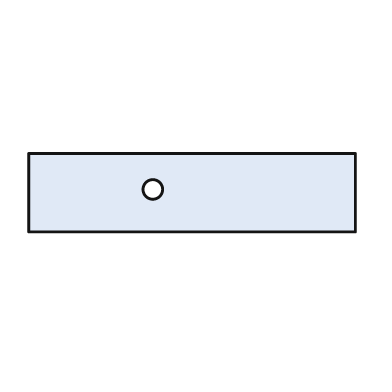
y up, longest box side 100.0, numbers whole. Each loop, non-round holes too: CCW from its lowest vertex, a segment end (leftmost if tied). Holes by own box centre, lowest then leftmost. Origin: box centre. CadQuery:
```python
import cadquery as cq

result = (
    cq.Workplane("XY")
    .moveTo(-50.0, -12.0)
    .lineTo(50.0, -12.0)
    .lineTo(50.0, 12.0)
    .lineTo(-50.0, 12.0)
    .close()
    .moveTo(-12.0, 1.0)
    .circle(3.0)
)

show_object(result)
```